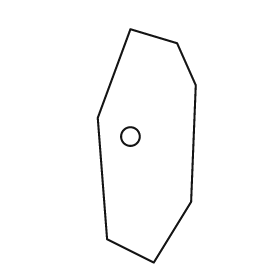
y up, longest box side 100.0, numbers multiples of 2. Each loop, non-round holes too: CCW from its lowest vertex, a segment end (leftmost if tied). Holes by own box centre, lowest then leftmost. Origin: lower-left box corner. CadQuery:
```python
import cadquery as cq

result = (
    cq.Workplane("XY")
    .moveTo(24.0, 0.0)
    .lineTo(40.0, 26.0)
    .lineTo(42.0, 76.0)
    .lineTo(34.0, 94.0)
    .lineTo(14.0, 100.0)
    .lineTo(0.0, 62.0)
    .lineTo(4.0, 10.0)
    .close()
    .moveTo(14.0, 54.0)
    .circle(4.0)
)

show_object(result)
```